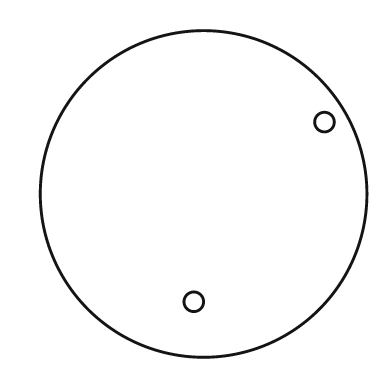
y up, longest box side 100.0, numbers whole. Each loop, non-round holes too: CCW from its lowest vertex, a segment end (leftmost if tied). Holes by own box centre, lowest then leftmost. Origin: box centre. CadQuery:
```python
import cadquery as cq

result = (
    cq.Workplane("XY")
    .moveTo(0.0, 0.0)
    .circle(50.0)
    .moveTo(-3.0, -33.0)
    .circle(3.0)
    .moveTo(37.0, 22.0)
    .circle(3.0)
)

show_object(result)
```